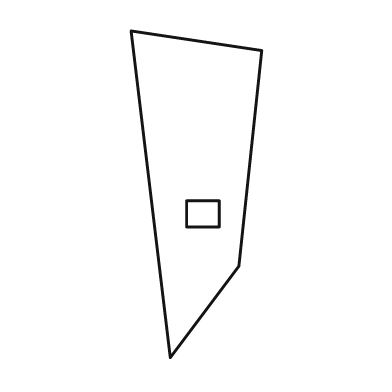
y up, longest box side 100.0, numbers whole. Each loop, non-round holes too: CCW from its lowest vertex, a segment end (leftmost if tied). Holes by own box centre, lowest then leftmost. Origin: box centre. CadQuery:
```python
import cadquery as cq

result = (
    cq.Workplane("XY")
    .moveTo(-8.0, -50.0)
    .lineTo(13.0, -22.0)
    .lineTo(20.0, 44.0)
    .lineTo(-20.0, 50.0)
    .close()
    .moveTo(-3.0, -10.0)
    .lineTo(7.0, -10.0)
    .lineTo(7.0, -2.0)
    .lineTo(-3.0, -2.0)
    .close()
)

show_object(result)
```